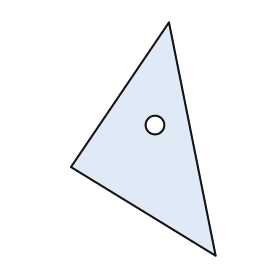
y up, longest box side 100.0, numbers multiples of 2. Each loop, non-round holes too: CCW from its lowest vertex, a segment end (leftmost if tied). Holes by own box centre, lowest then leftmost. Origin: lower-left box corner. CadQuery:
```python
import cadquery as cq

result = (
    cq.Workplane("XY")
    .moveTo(62.0, 0.0)
    .lineTo(42.0, 100.0)
    .lineTo(0.0, 38.0)
    .close()
    .moveTo(36.0, 56.0)
    .circle(4.0)
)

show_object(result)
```